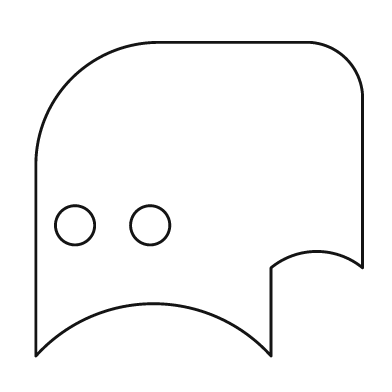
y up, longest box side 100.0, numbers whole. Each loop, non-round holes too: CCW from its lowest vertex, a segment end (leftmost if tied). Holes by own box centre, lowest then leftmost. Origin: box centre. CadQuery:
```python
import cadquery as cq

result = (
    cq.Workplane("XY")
    .moveTo(-50.0, -48.0)
    .threePointArc((-14.0, -32.0), (22.0, -48.0))
    .lineTo(22.0, -21.0)
    .threePointArc((36.0, -16.0), (50.0, -21.0))
    .lineTo(50.0, 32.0)
    .threePointArc((45.0, 43.0), (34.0, 48.0))
    .lineTo(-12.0, 48.0)
    .threePointArc((-39.0, 37.0), (-50.0, 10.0))
    .close()
    .moveTo(-38.0, -8.0)
    .circle(6.0)
    .moveTo(-15.0, -8.0)
    .circle(6.0)
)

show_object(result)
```